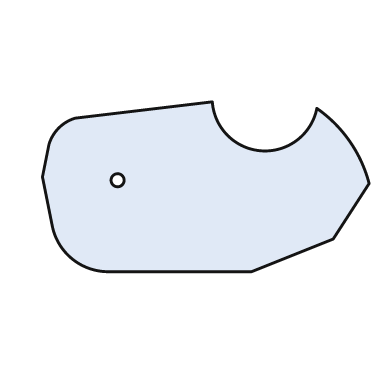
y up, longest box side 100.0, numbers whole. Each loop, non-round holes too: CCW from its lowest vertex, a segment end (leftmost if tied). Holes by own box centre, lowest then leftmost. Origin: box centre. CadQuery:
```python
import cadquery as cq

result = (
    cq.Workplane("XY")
    .moveTo(-30.0, -26.0)
    .lineTo(14.0, -26.0)
    .lineTo(39.0, -16.0)
    .lineTo(50.0, 1.0)
    .threePointArc((44.0, 14.0), (34.0, 24.0))
    .threePointArc((17.0, 11.0), (2.0, 26.0))
    .lineTo(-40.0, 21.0)
    .threePointArc((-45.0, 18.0), (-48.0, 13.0))
    .lineTo(-50.0, 3.0)
    .lineTo(-47.0, -12.0)
    .threePointArc((-41.0, -22.0), (-30.0, -26.0))
    .close()
    .moveTo(-27.0, 2.0)
    .circle(2.0)
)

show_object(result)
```